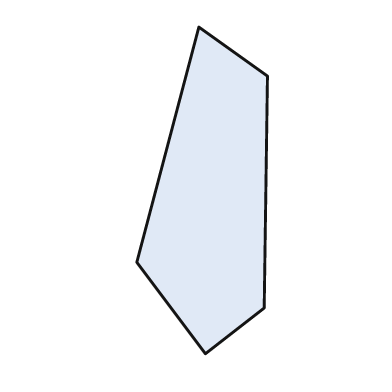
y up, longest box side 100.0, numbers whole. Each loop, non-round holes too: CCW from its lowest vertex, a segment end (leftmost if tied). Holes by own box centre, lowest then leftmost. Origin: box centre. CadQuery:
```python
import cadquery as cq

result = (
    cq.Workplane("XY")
    .moveTo(1.0, -50.0)
    .lineTo(19.0, -36.0)
    .lineTo(20.0, 35.0)
    .lineTo(-1.0, 50.0)
    .lineTo(-20.0, -22.0)
    .close()
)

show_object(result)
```